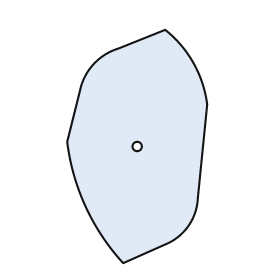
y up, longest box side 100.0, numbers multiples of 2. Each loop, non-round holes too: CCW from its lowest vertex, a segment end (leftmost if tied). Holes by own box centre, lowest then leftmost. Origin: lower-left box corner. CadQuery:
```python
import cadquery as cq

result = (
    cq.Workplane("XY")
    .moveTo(24.0, 0.0)
    .lineTo(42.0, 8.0)
    .threePointArc((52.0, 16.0), (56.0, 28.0))
    .lineTo(60.0, 68.0)
    .threePointArc((54.0, 86.0), (42.0, 100.0))
    .lineTo(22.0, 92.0)
    .threePointArc((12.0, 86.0), (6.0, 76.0))
    .lineTo(0.0, 52.0)
    .threePointArc((8.0, 24.0), (24.0, 0.0))
    .close()
    .moveTo(30.0, 50.0)
    .circle(2.0)
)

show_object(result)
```